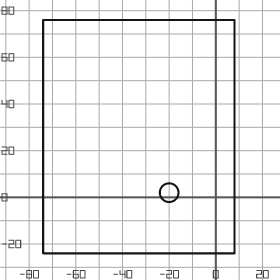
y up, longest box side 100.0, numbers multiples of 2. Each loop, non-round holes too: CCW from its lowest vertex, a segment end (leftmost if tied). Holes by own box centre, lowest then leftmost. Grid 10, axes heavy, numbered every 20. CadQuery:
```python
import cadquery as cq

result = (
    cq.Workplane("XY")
    .moveTo(-74.0, -24.0)
    .lineTo(8.0, -24.0)
    .lineTo(8.0, 76.0)
    .lineTo(-74.0, 76.0)
    .close()
    .moveTo(-20.0, 2.0)
    .circle(4.0)
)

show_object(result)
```